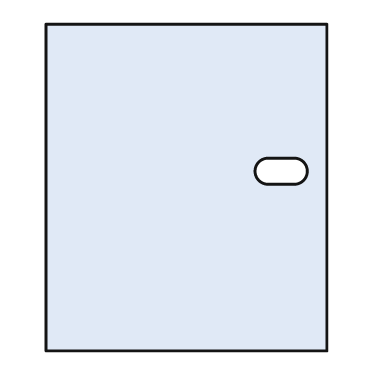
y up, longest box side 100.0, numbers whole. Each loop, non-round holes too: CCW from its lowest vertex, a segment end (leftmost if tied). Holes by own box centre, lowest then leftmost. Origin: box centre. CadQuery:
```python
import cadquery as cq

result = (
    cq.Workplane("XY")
    .moveTo(-43.0, -50.0)
    .lineTo(43.0, -50.0)
    .lineTo(43.0, 50.0)
    .lineTo(-43.0, 50.0)
    .close()
    .moveTo(25.0, 1.0)
    .lineTo(33.0, 1.0)
    .threePointArc((37.0, 5.0), (33.0, 9.0))
    .lineTo(25.0, 9.0)
    .threePointArc((21.0, 5.0), (25.0, 1.0))
    .close()
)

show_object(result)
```